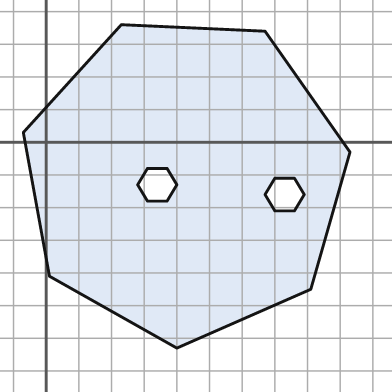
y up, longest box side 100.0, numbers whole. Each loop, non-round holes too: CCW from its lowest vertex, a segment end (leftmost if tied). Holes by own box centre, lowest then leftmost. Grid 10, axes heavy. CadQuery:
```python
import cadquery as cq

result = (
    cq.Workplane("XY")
    .moveTo(40.0, -63.0)
    .lineTo(81.0, -45.0)
    .lineTo(93.0, -3.0)
    .lineTo(67.0, 34.0)
    .lineTo(23.0, 36.0)
    .lineTo(-7.0, 3.0)
    .lineTo(1.0, -41.0)
    .close()
    .moveTo(70.0, -21.0)
    .lineTo(76.0, -21.0)
    .lineTo(79.0, -16.0)
    .lineTo(76.0, -11.0)
    .lineTo(70.0, -11.0)
    .lineTo(67.0, -16.0)
    .close()
    .moveTo(31.0, -18.0)
    .lineTo(37.0, -18.0)
    .lineTo(40.0, -13.0)
    .lineTo(37.0, -8.0)
    .lineTo(31.0, -8.0)
    .lineTo(28.0, -13.0)
    .close()
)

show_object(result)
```